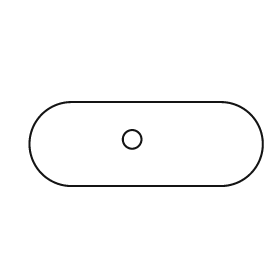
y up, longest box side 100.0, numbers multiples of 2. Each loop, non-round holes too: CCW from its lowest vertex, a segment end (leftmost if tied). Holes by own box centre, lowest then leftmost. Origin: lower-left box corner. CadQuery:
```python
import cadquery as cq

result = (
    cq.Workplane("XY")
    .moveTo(18.0, 0.0)
    .lineTo(82.0, 0.0)
    .threePointArc((100.0, 18.0), (82.0, 36.0))
    .lineTo(18.0, 36.0)
    .threePointArc((0.0, 18.0), (18.0, 0.0))
    .close()
    .moveTo(44.0, 20.0)
    .circle(4.0)
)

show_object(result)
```